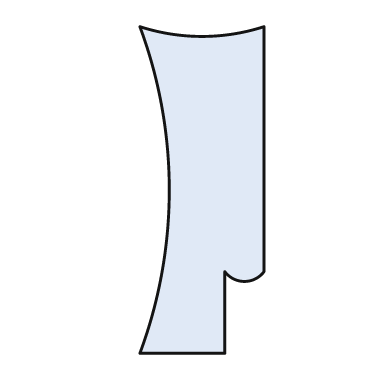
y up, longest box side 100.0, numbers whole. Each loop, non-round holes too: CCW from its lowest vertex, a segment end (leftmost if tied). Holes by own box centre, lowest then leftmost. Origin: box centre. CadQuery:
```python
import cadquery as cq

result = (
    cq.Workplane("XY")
    .moveTo(-19.0, -50.0)
    .lineTo(7.0, -50.0)
    .lineTo(7.0, -25.0)
    .threePointArc((13.0, -28.0), (19.0, -25.0))
    .lineTo(19.0, 50.0)
    .threePointArc((0.0, 47.0), (-19.0, 50.0))
    .threePointArc((-10.0, 0.0), (-19.0, -50.0))
    .close()
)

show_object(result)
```